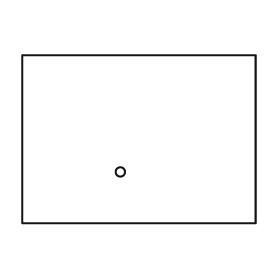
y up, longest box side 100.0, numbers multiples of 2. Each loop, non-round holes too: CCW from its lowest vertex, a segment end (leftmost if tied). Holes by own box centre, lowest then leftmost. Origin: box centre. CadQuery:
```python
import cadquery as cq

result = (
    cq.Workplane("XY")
    .moveTo(-50.0, -36.0)
    .lineTo(50.0, -36.0)
    .lineTo(50.0, 36.0)
    .lineTo(-50.0, 36.0)
    .close()
    .moveTo(-8.0, -14.0)
    .circle(2.0)
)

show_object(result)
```